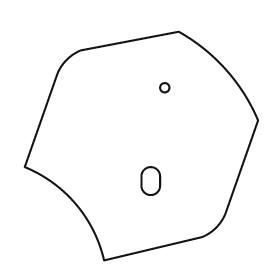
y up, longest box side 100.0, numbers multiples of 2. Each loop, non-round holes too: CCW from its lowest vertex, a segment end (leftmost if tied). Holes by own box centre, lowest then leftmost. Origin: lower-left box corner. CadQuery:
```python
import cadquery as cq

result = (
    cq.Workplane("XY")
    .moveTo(34.0, 0.0)
    .lineTo(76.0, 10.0)
    .threePointArc((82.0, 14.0), (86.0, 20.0))
    .lineTo(100.0, 60.0)
    .threePointArc((86.0, 82.0), (66.0, 98.0))
    .lineTo(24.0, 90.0)
    .threePointArc((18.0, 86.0), (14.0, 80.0))
    .lineTo(0.0, 40.0)
    .threePointArc((22.0, 24.0), (34.0, 0.0))
    .close()
    .moveTo(50.0, 32.0)
    .threePointArc((54.0, 28.0), (58.0, 32.0))
    .lineTo(58.0, 36.0)
    .threePointArc((54.0, 40.0), (50.0, 36.0))
    .close()
    .moveTo(60.0, 74.0)
    .circle(2.0)
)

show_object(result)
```